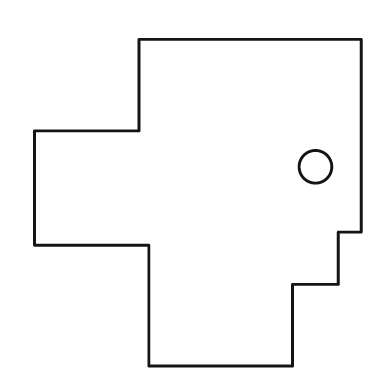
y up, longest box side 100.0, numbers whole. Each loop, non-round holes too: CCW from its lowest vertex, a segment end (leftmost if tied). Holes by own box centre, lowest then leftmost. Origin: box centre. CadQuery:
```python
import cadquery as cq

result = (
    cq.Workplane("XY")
    .moveTo(-15.0, -50.0)
    .lineTo(29.0, -50.0)
    .lineTo(29.0, -25.0)
    .lineTo(43.0, -25.0)
    .lineTo(43.0, -9.0)
    .lineTo(50.0, -9.0)
    .lineTo(50.0, 50.0)
    .lineTo(-18.0, 50.0)
    .lineTo(-18.0, 22.0)
    .lineTo(-50.0, 22.0)
    .lineTo(-50.0, -13.0)
    .lineTo(-15.0, -13.0)
    .close()
    .moveTo(36.0, 11.0)
    .circle(5.0)
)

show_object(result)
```